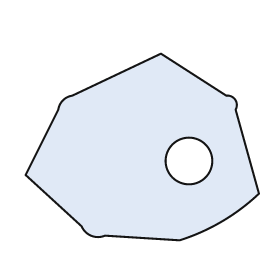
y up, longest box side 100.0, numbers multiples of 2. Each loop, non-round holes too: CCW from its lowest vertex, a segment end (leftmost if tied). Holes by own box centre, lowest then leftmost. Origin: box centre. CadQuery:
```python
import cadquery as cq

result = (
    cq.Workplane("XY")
    .moveTo(16.0, -40.0)
    .threePointArc((34.0, -32.0), (50.0, -20.0))
    .lineTo(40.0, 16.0)
    .threePointArc((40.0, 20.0), (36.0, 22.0))
    .lineTo(8.0, 40.0)
    .lineTo(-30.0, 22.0)
    .threePointArc((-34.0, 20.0), (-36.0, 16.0))
    .lineTo(-50.0, -12.0)
    .lineTo(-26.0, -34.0)
    .threePointArc((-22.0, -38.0), (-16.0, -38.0))
    .close()
    .moveTo(20.0, -6.0)
    .circle(10.0)
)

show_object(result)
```